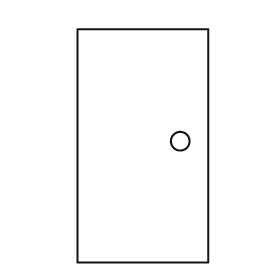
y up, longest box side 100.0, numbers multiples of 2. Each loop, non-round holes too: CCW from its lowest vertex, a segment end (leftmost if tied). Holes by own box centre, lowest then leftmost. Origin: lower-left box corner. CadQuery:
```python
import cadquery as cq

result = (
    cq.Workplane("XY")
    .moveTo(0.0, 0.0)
    .lineTo(56.0, 0.0)
    .lineTo(56.0, 100.0)
    .lineTo(0.0, 100.0)
    .close()
    .moveTo(44.0, 52.0)
    .circle(4.0)
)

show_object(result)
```